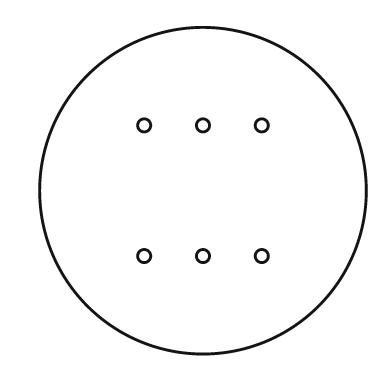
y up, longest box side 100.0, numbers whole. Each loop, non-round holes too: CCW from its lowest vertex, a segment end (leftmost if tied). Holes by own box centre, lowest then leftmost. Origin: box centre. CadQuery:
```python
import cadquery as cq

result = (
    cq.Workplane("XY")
    .moveTo(0.0, 0.0)
    .circle(50.0)
    .moveTo(-18.0, -20.0)
    .circle(2.0)
    .moveTo(0.0, -20.0)
    .circle(2.0)
    .moveTo(18.0, -20.0)
    .circle(2.0)
    .moveTo(-18.0, 20.0)
    .circle(2.0)
    .moveTo(0.0, 20.0)
    .circle(2.0)
    .moveTo(18.0, 20.0)
    .circle(2.0)
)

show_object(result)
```